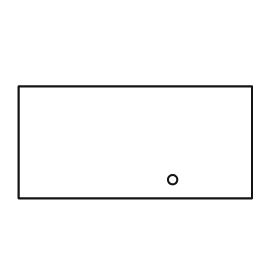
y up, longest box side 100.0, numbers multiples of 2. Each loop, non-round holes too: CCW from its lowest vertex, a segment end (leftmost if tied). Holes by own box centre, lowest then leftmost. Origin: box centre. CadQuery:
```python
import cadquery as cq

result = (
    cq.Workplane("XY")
    .moveTo(-50.0, -24.0)
    .lineTo(50.0, -24.0)
    .lineTo(50.0, 24.0)
    .lineTo(-50.0, 24.0)
    .close()
    .moveTo(16.0, -16.0)
    .circle(2.0)
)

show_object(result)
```